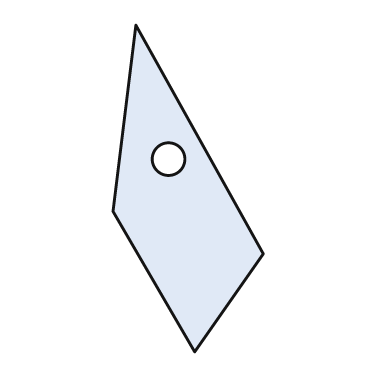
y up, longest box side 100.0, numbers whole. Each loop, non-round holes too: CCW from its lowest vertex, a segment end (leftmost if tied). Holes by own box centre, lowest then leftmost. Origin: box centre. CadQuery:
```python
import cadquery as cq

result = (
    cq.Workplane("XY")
    .moveTo(2.0, -50.0)
    .lineTo(23.0, -20.0)
    .lineTo(-16.0, 50.0)
    .lineTo(-23.0, -7.0)
    .close()
    .moveTo(-6.0, 9.0)
    .circle(5.0)
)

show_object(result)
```